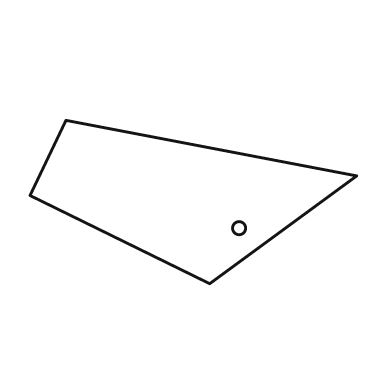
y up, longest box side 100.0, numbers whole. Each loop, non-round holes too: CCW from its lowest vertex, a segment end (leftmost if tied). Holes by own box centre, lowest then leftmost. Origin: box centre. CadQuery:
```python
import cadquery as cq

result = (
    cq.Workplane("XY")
    .moveTo(5.0, -25.0)
    .lineTo(50.0, 8.0)
    .lineTo(-39.0, 25.0)
    .lineTo(-50.0, 2.0)
    .close()
    .moveTo(14.0, -8.0)
    .circle(2.0)
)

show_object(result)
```